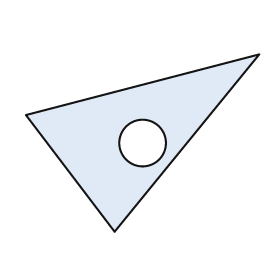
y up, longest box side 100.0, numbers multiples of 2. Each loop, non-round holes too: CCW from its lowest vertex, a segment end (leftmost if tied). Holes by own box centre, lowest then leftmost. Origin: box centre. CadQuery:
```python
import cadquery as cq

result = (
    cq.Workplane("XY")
    .moveTo(-12.0, -38.0)
    .lineTo(50.0, 38.0)
    .lineTo(-50.0, 12.0)
    .close()
    .moveTo(0.0, 0.0)
    .circle(10.0)
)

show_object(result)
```